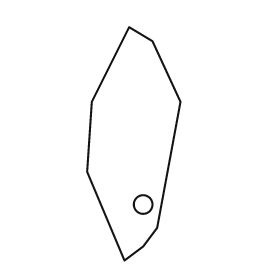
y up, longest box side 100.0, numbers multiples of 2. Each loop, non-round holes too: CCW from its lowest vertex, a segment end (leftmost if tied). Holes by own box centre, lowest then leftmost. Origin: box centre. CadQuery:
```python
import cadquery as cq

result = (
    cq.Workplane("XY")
    .moveTo(-4.0, -50.0)
    .lineTo(4.0, -44.0)
    .lineTo(10.0, -36.0)
    .lineTo(20.0, 18.0)
    .lineTo(8.0, 44.0)
    .lineTo(-2.0, 50.0)
    .lineTo(-18.0, 18.0)
    .lineTo(-20.0, -12.0)
    .close()
    .moveTo(4.0, -26.0)
    .circle(4.0)
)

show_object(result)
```